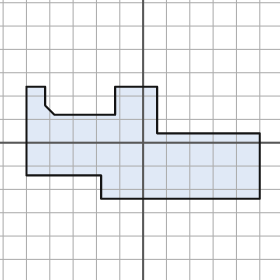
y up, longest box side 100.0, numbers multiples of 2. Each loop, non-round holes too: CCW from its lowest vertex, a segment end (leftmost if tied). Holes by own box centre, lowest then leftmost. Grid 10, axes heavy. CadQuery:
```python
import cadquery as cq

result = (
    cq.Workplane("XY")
    .moveTo(-18.0, -24.0)
    .lineTo(50.0, -24.0)
    .lineTo(50.0, 4.0)
    .lineTo(6.0, 4.0)
    .lineTo(6.0, 24.0)
    .lineTo(-12.0, 24.0)
    .lineTo(-12.0, 12.0)
    .lineTo(-38.0, 12.0)
    .lineTo(-42.0, 16.0)
    .lineTo(-42.0, 24.0)
    .lineTo(-50.0, 24.0)
    .lineTo(-50.0, -14.0)
    .lineTo(-18.0, -14.0)
    .close()
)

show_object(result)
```